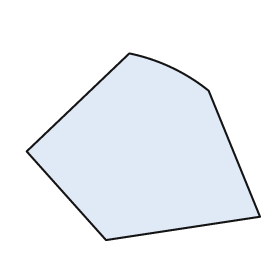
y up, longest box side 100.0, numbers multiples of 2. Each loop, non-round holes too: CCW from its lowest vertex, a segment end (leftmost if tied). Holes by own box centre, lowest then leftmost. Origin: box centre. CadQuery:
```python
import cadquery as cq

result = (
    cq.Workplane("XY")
    .moveTo(-16.0, -40.0)
    .lineTo(50.0, -30.0)
    .lineTo(28.0, 24.0)
    .threePointArc((12.0, 34.0), (-6.0, 40.0))
    .lineTo(-50.0, -2.0)
    .close()
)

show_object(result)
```